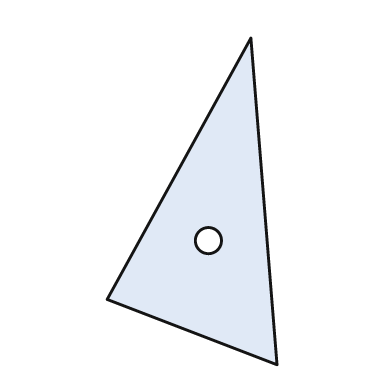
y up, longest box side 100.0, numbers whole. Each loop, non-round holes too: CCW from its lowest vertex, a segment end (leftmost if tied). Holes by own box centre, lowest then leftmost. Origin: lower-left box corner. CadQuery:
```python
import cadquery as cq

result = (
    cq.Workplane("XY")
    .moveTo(52.0, 0.0)
    .lineTo(44.0, 100.0)
    .lineTo(0.0, 20.0)
    .close()
    .moveTo(31.0, 38.0)
    .circle(4.0)
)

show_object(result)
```